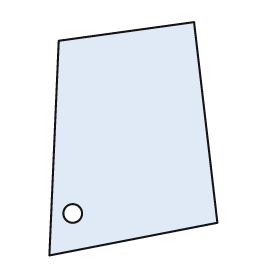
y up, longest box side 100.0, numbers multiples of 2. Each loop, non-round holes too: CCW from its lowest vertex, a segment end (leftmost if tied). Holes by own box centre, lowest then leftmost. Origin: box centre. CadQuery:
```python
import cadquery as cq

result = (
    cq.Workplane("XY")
    .moveTo(-36.0, -50.0)
    .lineTo(36.0, -36.0)
    .lineTo(26.0, 50.0)
    .lineTo(-32.0, 42.0)
    .close()
    .moveTo(-26.0, -32.0)
    .circle(4.0)
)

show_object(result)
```